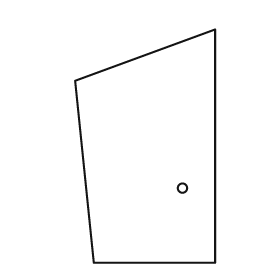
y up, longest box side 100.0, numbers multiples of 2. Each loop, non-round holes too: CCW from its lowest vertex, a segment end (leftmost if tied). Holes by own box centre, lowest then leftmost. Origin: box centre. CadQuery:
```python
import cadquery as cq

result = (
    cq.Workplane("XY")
    .moveTo(-22.0, -50.0)
    .lineTo(30.0, -50.0)
    .lineTo(30.0, 50.0)
    .lineTo(-30.0, 28.0)
    .close()
    .moveTo(16.0, -18.0)
    .circle(2.0)
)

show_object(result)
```